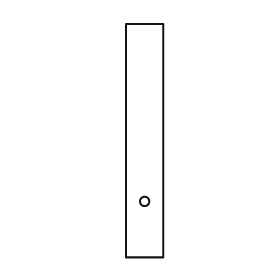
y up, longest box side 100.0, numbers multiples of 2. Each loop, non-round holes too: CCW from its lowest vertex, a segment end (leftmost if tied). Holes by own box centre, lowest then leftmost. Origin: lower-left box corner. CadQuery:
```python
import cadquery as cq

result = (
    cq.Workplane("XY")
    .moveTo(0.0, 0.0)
    .lineTo(16.0, 0.0)
    .lineTo(16.0, 100.0)
    .lineTo(0.0, 100.0)
    .close()
    .moveTo(8.0, 24.0)
    .circle(2.0)
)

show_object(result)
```